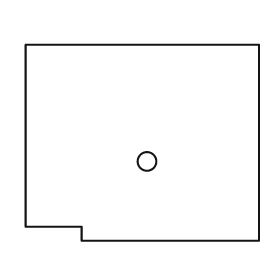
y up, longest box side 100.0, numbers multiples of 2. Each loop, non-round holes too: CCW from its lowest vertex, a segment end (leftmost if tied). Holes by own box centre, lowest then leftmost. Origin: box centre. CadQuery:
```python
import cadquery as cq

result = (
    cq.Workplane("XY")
    .moveTo(-26.0, -42.0)
    .lineTo(50.0, -42.0)
    .lineTo(50.0, 42.0)
    .lineTo(-50.0, 42.0)
    .lineTo(-50.0, -36.0)
    .lineTo(-26.0, -36.0)
    .close()
    .moveTo(2.0, -8.0)
    .circle(4.0)
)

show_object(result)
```